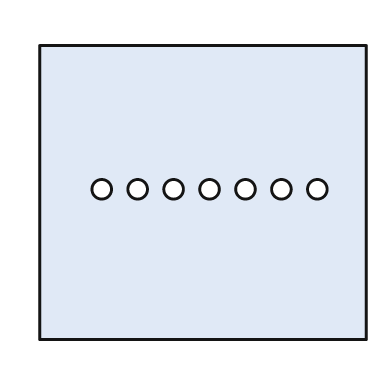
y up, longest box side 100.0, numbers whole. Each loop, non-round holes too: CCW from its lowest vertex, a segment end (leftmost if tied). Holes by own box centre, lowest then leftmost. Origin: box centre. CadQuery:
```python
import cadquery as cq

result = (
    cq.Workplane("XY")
    .moveTo(-50.0, -45.0)
    .lineTo(50.0, -45.0)
    .lineTo(50.0, 45.0)
    .lineTo(-50.0, 45.0)
    .close()
    .moveTo(-31.0, 1.0)
    .circle(3.0)
    .moveTo(-20.0, 1.0)
    .circle(3.0)
    .moveTo(-9.0, 1.0)
    .circle(3.0)
    .moveTo(2.0, 1.0)
    .circle(3.0)
    .moveTo(13.0, 1.0)
    .circle(3.0)
    .moveTo(24.0, 1.0)
    .circle(3.0)
    .moveTo(35.0, 1.0)
    .circle(3.0)
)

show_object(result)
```